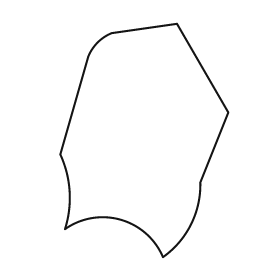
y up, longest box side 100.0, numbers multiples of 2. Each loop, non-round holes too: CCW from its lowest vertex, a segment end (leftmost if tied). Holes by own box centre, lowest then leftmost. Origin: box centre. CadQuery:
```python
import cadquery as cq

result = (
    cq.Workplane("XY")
    .moveTo(8.0, -50.0)
    .threePointArc((20.0, -36.0), (24.0, -18.0))
    .lineTo(36.0, 12.0)
    .lineTo(14.0, 50.0)
    .lineTo(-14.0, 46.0)
    .threePointArc((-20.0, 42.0), (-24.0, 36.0))
    .lineTo(-36.0, -6.0)
    .threePointArc((-32.0, -22.0), (-34.0, -38.0))
    .threePointArc((-10.0, -34.0), (8.0, -50.0))
    .close()
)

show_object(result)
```